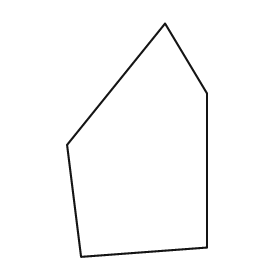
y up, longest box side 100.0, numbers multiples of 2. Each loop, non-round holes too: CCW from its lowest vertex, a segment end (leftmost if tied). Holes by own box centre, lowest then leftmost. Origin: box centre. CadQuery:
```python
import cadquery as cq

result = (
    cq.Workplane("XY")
    .moveTo(-24.0, -50.0)
    .lineTo(30.0, -46.0)
    .lineTo(30.0, 20.0)
    .lineTo(12.0, 50.0)
    .lineTo(-30.0, -2.0)
    .close()
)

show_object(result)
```